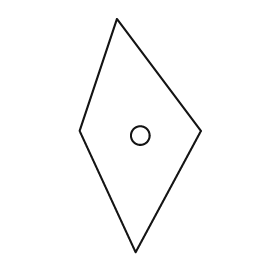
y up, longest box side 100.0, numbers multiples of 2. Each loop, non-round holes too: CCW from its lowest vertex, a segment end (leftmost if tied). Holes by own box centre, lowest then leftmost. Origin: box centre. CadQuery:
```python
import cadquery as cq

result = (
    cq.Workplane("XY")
    .moveTo(-2.0, -50.0)
    .lineTo(26.0, 2.0)
    .lineTo(-10.0, 50.0)
    .lineTo(-26.0, 2.0)
    .close()
    .moveTo(0.0, 0.0)
    .circle(4.0)
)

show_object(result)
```